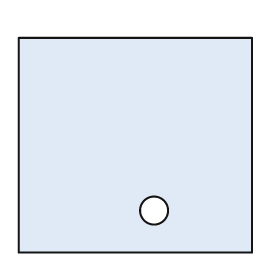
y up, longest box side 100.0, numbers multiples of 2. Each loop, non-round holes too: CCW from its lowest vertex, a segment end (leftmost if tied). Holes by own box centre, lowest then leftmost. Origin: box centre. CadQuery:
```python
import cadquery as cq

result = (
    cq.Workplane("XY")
    .moveTo(-50.0, -46.0)
    .lineTo(50.0, -46.0)
    .lineTo(50.0, 46.0)
    .lineTo(-50.0, 46.0)
    .close()
    .moveTo(8.0, -28.0)
    .circle(6.0)
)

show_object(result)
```